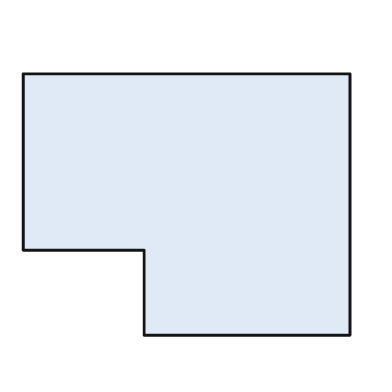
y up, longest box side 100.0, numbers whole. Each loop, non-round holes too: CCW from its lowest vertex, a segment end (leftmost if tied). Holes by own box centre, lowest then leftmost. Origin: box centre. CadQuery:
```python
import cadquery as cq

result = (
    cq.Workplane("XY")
    .moveTo(-13.0, -40.0)
    .lineTo(50.0, -40.0)
    .lineTo(50.0, 40.0)
    .lineTo(-50.0, 40.0)
    .lineTo(-50.0, -14.0)
    .lineTo(-13.0, -14.0)
    .close()
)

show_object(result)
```